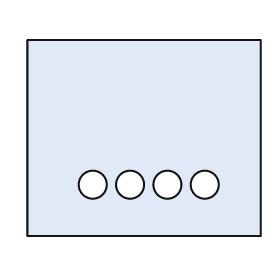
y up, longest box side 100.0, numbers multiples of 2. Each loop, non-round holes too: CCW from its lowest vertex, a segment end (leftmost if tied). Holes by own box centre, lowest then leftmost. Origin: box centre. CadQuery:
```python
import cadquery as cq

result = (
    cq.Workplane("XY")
    .moveTo(-50.0, -42.0)
    .lineTo(50.0, -42.0)
    .lineTo(50.0, 42.0)
    .lineTo(-50.0, 42.0)
    .close()
    .moveTo(-22.0, -20.0)
    .circle(6.0)
    .moveTo(-6.0, -20.0)
    .circle(6.0)
    .moveTo(10.0, -20.0)
    .circle(6.0)
    .moveTo(26.0, -20.0)
    .circle(6.0)
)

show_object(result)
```